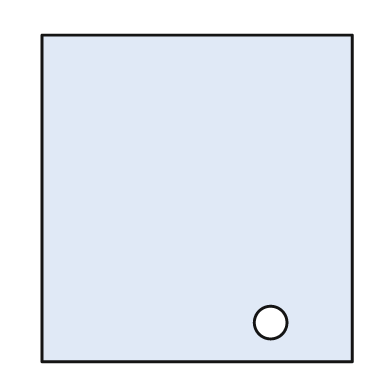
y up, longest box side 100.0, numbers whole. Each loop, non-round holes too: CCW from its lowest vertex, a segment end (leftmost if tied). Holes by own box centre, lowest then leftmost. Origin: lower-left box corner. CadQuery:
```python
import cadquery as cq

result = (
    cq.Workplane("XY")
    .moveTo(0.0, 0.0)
    .lineTo(95.0, 0.0)
    .lineTo(95.0, 100.0)
    .lineTo(0.0, 100.0)
    .close()
    .moveTo(70.0, 12.0)
    .circle(5.0)
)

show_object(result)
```